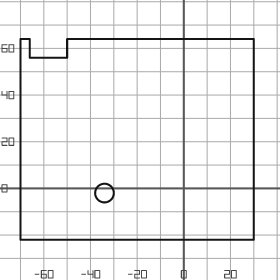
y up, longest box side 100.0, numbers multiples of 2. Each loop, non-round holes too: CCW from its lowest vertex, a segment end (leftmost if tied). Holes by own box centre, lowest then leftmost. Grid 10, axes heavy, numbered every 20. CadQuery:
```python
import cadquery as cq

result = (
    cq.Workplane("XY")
    .moveTo(-70.0, -22.0)
    .lineTo(30.0, -22.0)
    .lineTo(30.0, 64.0)
    .lineTo(-50.0, 64.0)
    .lineTo(-50.0, 56.0)
    .lineTo(-66.0, 56.0)
    .lineTo(-66.0, 64.0)
    .lineTo(-70.0, 64.0)
    .close()
    .moveTo(-34.0, -2.0)
    .circle(4.0)
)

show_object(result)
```